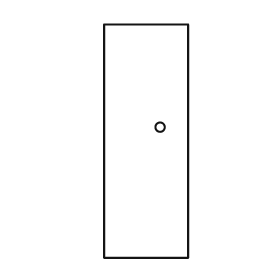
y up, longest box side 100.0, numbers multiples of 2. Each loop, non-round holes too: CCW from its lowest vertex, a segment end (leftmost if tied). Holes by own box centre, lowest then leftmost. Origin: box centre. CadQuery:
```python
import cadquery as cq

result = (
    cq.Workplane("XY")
    .moveTo(-18.0, -50.0)
    .lineTo(18.0, -50.0)
    .lineTo(18.0, 50.0)
    .lineTo(-18.0, 50.0)
    .close()
    .moveTo(6.0, 6.0)
    .circle(2.0)
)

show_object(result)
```